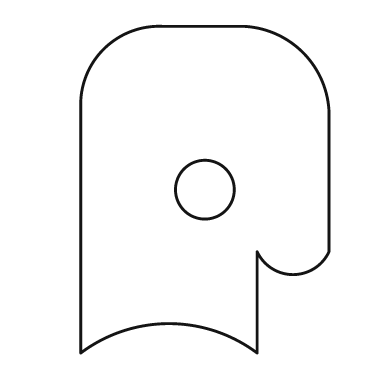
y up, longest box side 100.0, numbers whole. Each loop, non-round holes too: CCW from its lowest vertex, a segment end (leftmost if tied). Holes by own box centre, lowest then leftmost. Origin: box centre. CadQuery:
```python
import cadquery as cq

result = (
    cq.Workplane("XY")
    .moveTo(-38.0, -50.0)
    .threePointArc((-11.0, -41.0), (16.0, -50.0))
    .lineTo(16.0, -19.0)
    .threePointArc((27.0, -26.0), (38.0, -19.0))
    .lineTo(38.0, 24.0)
    .threePointArc((30.0, 42.0), (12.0, 50.0))
    .lineTo(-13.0, 50.0)
    .threePointArc((-31.0, 43.0), (-38.0, 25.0))
    .close()
    .moveTo(0.0, 0.0)
    .circle(9.0)
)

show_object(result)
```